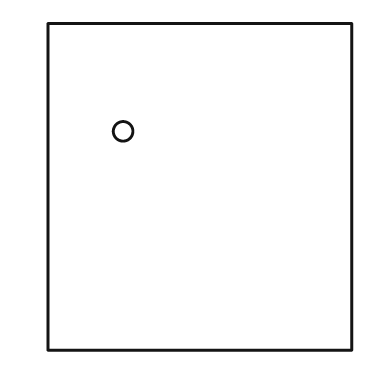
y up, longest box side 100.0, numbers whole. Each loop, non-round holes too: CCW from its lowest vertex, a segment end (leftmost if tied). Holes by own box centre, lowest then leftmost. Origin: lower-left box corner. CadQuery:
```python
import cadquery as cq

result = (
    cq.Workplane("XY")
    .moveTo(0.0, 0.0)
    .lineTo(93.0, 0.0)
    .lineTo(93.0, 100.0)
    .lineTo(0.0, 100.0)
    .close()
    .moveTo(23.0, 67.0)
    .circle(3.0)
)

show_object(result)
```